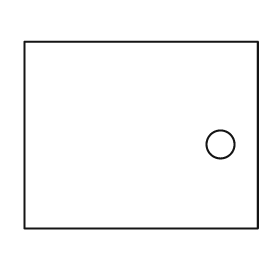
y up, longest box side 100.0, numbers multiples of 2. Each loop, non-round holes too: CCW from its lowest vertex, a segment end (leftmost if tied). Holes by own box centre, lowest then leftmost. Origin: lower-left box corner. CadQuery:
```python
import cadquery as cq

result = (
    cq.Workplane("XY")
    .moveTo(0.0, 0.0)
    .lineTo(100.0, 0.0)
    .lineTo(100.0, 80.0)
    .lineTo(0.0, 80.0)
    .close()
    .moveTo(84.0, 36.0)
    .circle(6.0)
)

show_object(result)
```